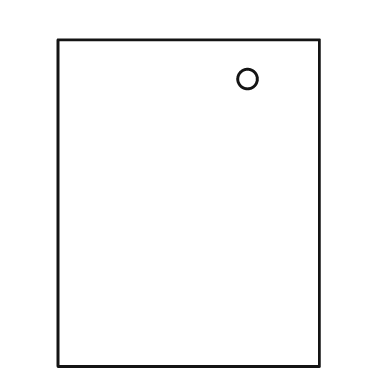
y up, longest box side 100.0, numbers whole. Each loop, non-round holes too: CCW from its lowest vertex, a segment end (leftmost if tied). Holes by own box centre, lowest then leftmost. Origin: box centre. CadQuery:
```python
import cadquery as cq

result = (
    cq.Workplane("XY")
    .moveTo(-40.0, -50.0)
    .lineTo(40.0, -50.0)
    .lineTo(40.0, 50.0)
    .lineTo(-40.0, 50.0)
    .close()
    .moveTo(18.0, 38.0)
    .circle(3.0)
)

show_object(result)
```